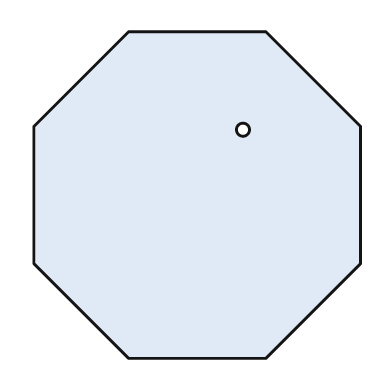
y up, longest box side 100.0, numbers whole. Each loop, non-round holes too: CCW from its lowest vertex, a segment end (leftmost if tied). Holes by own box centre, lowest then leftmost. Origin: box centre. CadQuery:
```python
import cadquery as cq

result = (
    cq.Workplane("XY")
    .moveTo(-21.0, -50.0)
    .lineTo(21.0, -50.0)
    .lineTo(50.0, -21.0)
    .lineTo(50.0, 21.0)
    .lineTo(21.0, 50.0)
    .lineTo(-21.0, 50.0)
    .lineTo(-50.0, 21.0)
    .lineTo(-50.0, -21.0)
    .close()
    .moveTo(14.0, 20.0)
    .circle(2.0)
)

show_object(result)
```